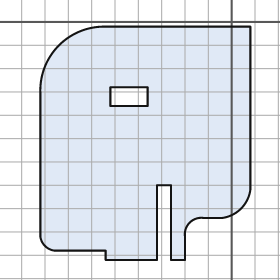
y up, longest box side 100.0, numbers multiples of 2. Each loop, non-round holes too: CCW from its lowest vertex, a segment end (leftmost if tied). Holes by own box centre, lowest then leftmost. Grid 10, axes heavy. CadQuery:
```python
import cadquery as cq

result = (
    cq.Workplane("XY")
    .moveTo(-54.0, -102.0)
    .lineTo(-32.0, -102.0)
    .lineTo(-32.0, -70.0)
    .lineTo(-26.0, -70.0)
    .lineTo(-26.0, -102.0)
    .lineTo(-20.0, -102.0)
    .lineTo(-20.0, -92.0)
    .threePointArc((-18.0, -86.0), (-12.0, -84.0))
    .lineTo(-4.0, -84.0)
    .threePointArc((4.0, -80.0), (8.0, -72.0))
    .lineTo(8.0, -2.0)
    .lineTo(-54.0, -2.0)
    .threePointArc((-74.0, -10.0), (-82.0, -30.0))
    .lineTo(-82.0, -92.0)
    .threePointArc((-80.0, -96.0), (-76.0, -98.0))
    .lineTo(-54.0, -98.0)
    .close()
    .moveTo(-52.0, -36.0)
    .lineTo(-36.0, -36.0)
    .lineTo(-36.0, -28.0)
    .lineTo(-52.0, -28.0)
    .close()
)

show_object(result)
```